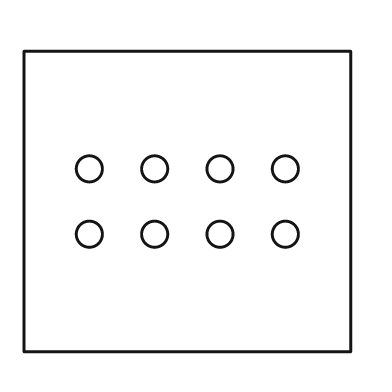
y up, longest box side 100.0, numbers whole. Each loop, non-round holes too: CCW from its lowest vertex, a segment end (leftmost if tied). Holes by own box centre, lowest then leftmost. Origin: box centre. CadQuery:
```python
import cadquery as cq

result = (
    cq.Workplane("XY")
    .moveTo(-50.0, -46.0)
    .lineTo(50.0, -46.0)
    .lineTo(50.0, 46.0)
    .lineTo(-50.0, 46.0)
    .close()
    .moveTo(-30.0, -10.0)
    .circle(4.0)
    .moveTo(-10.0, -10.0)
    .circle(4.0)
    .moveTo(10.0, -10.0)
    .circle(4.0)
    .moveTo(30.0, -10.0)
    .circle(4.0)
    .moveTo(-30.0, 10.0)
    .circle(4.0)
    .moveTo(-10.0, 10.0)
    .circle(4.0)
    .moveTo(10.0, 10.0)
    .circle(4.0)
    .moveTo(30.0, 10.0)
    .circle(4.0)
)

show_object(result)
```